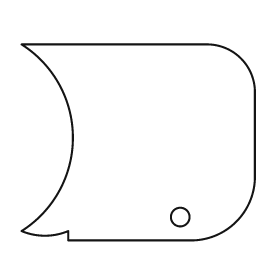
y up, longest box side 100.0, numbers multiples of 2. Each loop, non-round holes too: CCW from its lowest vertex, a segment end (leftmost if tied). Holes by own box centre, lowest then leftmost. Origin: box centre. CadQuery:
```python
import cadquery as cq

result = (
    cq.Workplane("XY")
    .moveTo(-30.0, -42.0)
    .lineTo(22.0, -42.0)
    .threePointArc((42.0, -34.0), (50.0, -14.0))
    .lineTo(50.0, 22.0)
    .threePointArc((44.0, 36.0), (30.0, 42.0))
    .lineTo(-50.0, 42.0)
    .threePointArc((-28.0, 2.0), (-50.0, -38.0))
    .threePointArc((-40.0, -40.0), (-30.0, -38.0))
    .close()
    .moveTo(18.0, -32.0)
    .circle(4.0)
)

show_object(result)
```